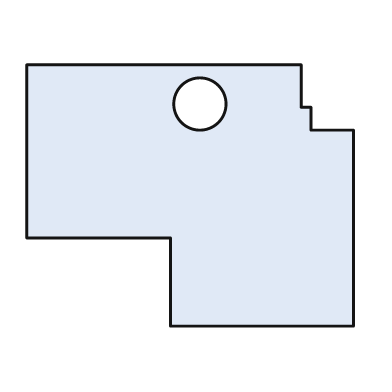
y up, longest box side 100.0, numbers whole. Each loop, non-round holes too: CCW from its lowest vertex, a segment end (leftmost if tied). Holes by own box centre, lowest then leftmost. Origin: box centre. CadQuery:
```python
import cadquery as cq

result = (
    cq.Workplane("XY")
    .moveTo(-6.0, -40.0)
    .lineTo(50.0, -40.0)
    .lineTo(50.0, 20.0)
    .lineTo(37.0, 20.0)
    .lineTo(37.0, 27.0)
    .lineTo(34.0, 27.0)
    .lineTo(34.0, 40.0)
    .lineTo(-50.0, 40.0)
    .lineTo(-50.0, -13.0)
    .lineTo(-6.0, -13.0)
    .close()
    .moveTo(3.0, 28.0)
    .circle(8.0)
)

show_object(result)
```